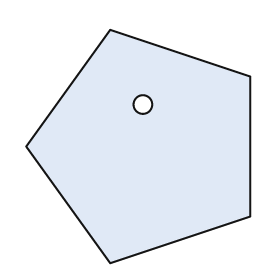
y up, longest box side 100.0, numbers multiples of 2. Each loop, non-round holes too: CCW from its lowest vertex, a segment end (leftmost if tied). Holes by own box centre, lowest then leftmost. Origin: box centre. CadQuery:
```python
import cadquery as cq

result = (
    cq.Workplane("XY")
    .moveTo(-12.0, -50.0)
    .lineTo(48.0, -30.0)
    .lineTo(48.0, 30.0)
    .lineTo(-12.0, 50.0)
    .lineTo(-48.0, 0.0)
    .close()
    .moveTo(2.0, 18.0)
    .circle(4.0)
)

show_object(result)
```